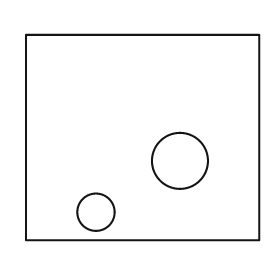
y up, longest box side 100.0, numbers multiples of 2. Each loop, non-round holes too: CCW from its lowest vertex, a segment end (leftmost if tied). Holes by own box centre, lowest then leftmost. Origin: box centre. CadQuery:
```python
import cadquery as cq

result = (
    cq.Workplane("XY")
    .moveTo(-50.0, -44.0)
    .lineTo(50.0, -44.0)
    .lineTo(50.0, 44.0)
    .lineTo(-50.0, 44.0)
    .close()
    .moveTo(-20.0, -32.0)
    .circle(8.0)
    .moveTo(16.0, -10.0)
    .circle(12.0)
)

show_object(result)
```